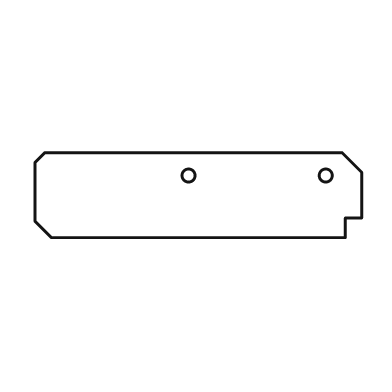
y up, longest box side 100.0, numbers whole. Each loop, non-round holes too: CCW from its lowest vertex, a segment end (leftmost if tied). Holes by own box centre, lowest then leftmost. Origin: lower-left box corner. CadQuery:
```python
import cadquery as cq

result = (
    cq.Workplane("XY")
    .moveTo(5.0, 0.0)
    .lineTo(95.0, 0.0)
    .lineTo(95.0, 6.0)
    .lineTo(100.0, 6.0)
    .lineTo(100.0, 20.0)
    .lineTo(94.0, 26.0)
    .lineTo(3.0, 26.0)
    .lineTo(0.0, 23.0)
    .lineTo(0.0, 5.0)
    .close()
    .moveTo(47.0, 19.0)
    .circle(2.0)
    .moveTo(89.0, 19.0)
    .circle(2.0)
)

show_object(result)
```